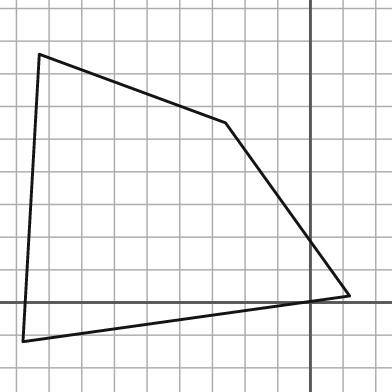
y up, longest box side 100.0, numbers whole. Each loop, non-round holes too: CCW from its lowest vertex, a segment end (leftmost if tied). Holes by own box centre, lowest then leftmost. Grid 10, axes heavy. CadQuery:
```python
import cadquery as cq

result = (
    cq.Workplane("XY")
    .moveTo(-88.0, -12.0)
    .lineTo(12.0, 2.0)
    .lineTo(-26.0, 55.0)
    .lineTo(-83.0, 76.0)
    .close()
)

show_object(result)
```